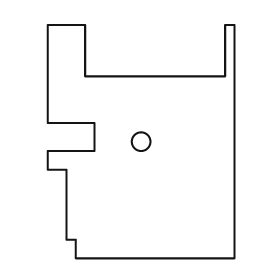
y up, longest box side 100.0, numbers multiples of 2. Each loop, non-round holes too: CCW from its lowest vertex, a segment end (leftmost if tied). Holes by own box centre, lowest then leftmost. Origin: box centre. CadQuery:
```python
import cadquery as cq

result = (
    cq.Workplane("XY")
    .moveTo(-28.0, -50.0)
    .lineTo(40.0, -50.0)
    .lineTo(40.0, 50.0)
    .lineTo(36.0, 50.0)
    .lineTo(36.0, 28.0)
    .lineTo(-24.0, 28.0)
    .lineTo(-24.0, 50.0)
    .lineTo(-40.0, 50.0)
    .lineTo(-40.0, 8.0)
    .lineTo(-20.0, 8.0)
    .lineTo(-20.0, -4.0)
    .lineTo(-40.0, -4.0)
    .lineTo(-40.0, -12.0)
    .lineTo(-32.0, -12.0)
    .lineTo(-32.0, -42.0)
    .lineTo(-28.0, -42.0)
    .close()
    .moveTo(0.0, 0.0)
    .circle(4.0)
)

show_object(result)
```